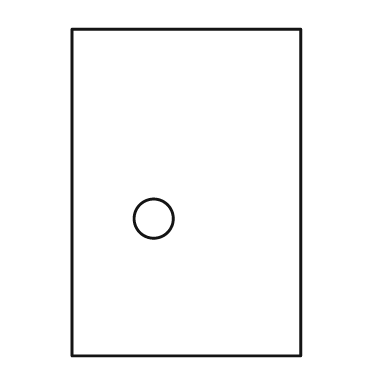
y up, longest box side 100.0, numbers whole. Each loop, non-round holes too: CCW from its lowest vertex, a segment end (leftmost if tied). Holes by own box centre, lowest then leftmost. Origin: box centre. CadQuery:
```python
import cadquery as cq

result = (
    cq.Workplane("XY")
    .moveTo(-35.0, -50.0)
    .lineTo(35.0, -50.0)
    .lineTo(35.0, 50.0)
    .lineTo(-35.0, 50.0)
    .close()
    .moveTo(-10.0, -8.0)
    .circle(6.0)
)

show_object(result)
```